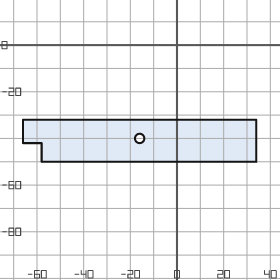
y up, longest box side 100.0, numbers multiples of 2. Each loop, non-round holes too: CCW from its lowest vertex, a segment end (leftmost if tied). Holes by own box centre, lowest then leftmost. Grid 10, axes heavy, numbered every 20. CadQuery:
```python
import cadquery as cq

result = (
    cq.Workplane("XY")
    .moveTo(-58.0, -50.0)
    .lineTo(34.0, -50.0)
    .lineTo(34.0, -32.0)
    .lineTo(-66.0, -32.0)
    .lineTo(-66.0, -42.0)
    .lineTo(-58.0, -42.0)
    .close()
    .moveTo(-16.0, -40.0)
    .circle(2.0)
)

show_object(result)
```